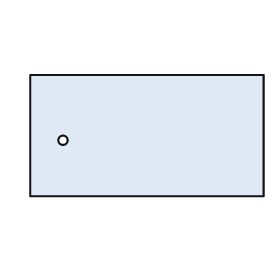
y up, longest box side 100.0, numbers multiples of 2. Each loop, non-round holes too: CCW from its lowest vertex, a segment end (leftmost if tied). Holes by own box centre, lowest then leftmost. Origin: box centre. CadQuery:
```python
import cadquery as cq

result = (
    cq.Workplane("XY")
    .moveTo(-50.0, -26.0)
    .lineTo(50.0, -26.0)
    .lineTo(50.0, 26.0)
    .lineTo(-50.0, 26.0)
    .close()
    .moveTo(-36.0, -2.0)
    .circle(2.0)
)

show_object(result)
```